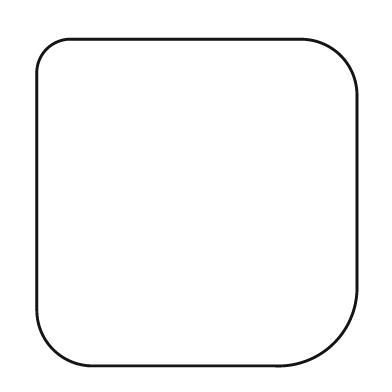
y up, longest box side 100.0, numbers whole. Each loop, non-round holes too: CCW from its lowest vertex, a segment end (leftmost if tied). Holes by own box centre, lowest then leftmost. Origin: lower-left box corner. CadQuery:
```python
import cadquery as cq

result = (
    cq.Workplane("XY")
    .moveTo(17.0, 0.0)
    .lineTo(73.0, 0.0)
    .threePointArc((91.0, 7.0), (98.0, 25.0))
    .lineTo(98.0, 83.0)
    .threePointArc((93.0, 95.0), (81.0, 100.0))
    .lineTo(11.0, 100.0)
    .threePointArc((3.0, 97.0), (0.0, 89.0))
    .lineTo(0.0, 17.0)
    .threePointArc((5.0, 5.0), (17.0, 0.0))
    .close()
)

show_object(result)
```